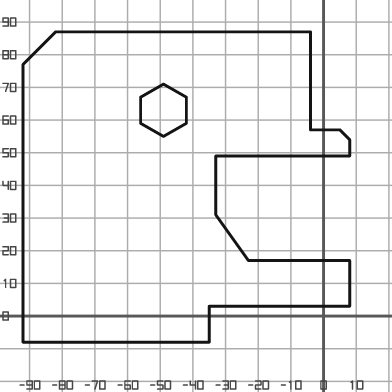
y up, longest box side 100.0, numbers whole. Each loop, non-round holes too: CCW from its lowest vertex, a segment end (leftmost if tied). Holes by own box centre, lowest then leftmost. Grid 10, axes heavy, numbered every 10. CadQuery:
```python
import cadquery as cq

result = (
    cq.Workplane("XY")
    .moveTo(-92.0, -8.0)
    .lineTo(-35.0, -8.0)
    .lineTo(-35.0, 3.0)
    .lineTo(8.0, 3.0)
    .lineTo(8.0, 17.0)
    .lineTo(-23.0, 17.0)
    .lineTo(-33.0, 31.0)
    .lineTo(-33.0, 49.0)
    .lineTo(8.0, 49.0)
    .lineTo(8.0, 54.0)
    .lineTo(5.0, 57.0)
    .lineTo(-4.0, 57.0)
    .lineTo(-4.0, 87.0)
    .lineTo(-82.0, 87.0)
    .lineTo(-92.0, 77.0)
    .close()
    .moveTo(-49.0, 55.0)
    .lineTo(-42.0, 59.0)
    .lineTo(-42.0, 67.0)
    .lineTo(-49.0, 71.0)
    .lineTo(-56.0, 67.0)
    .lineTo(-56.0, 59.0)
    .close()
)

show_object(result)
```